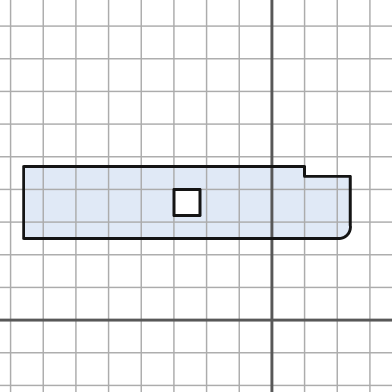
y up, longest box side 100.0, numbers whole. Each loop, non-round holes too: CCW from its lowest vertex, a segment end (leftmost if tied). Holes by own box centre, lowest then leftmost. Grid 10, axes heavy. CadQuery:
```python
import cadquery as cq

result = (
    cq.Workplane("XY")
    .moveTo(-76.0, 25.0)
    .lineTo(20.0, 25.0)
    .threePointArc((23.0, 26.0), (24.0, 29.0))
    .lineTo(24.0, 44.0)
    .lineTo(10.0, 44.0)
    .lineTo(10.0, 47.0)
    .lineTo(-76.0, 47.0)
    .close()
    .moveTo(-30.0, 32.0)
    .lineTo(-22.0, 32.0)
    .lineTo(-22.0, 40.0)
    .lineTo(-30.0, 40.0)
    .close()
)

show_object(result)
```